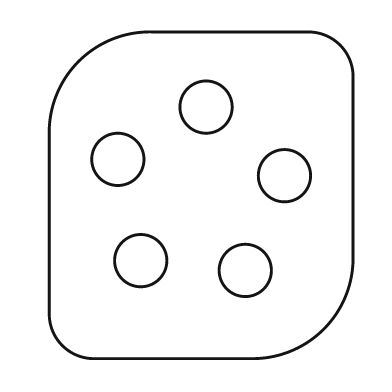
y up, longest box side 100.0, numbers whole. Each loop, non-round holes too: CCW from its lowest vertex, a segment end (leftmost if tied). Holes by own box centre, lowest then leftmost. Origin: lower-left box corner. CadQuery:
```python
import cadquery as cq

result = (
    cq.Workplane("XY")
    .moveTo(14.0, 0.0)
    .lineTo(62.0, 0.0)
    .threePointArc((84.0, 9.0), (93.0, 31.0))
    .lineTo(93.0, 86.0)
    .threePointArc((89.0, 96.0), (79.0, 100.0))
    .lineTo(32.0, 100.0)
    .threePointArc((9.0, 91.0), (0.0, 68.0))
    .lineTo(0.0, 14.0)
    .threePointArc((4.0, 4.0), (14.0, 0.0))
    .close()
    .moveTo(60.0, 27.0)
    .circle(8.0)
    .moveTo(28.0, 30.0)
    .circle(8.0)
    .moveTo(72.0, 56.0)
    .circle(8.0)
    .moveTo(21.0, 61.0)
    .circle(8.0)
    .moveTo(48.0, 77.0)
    .circle(8.0)
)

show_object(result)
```